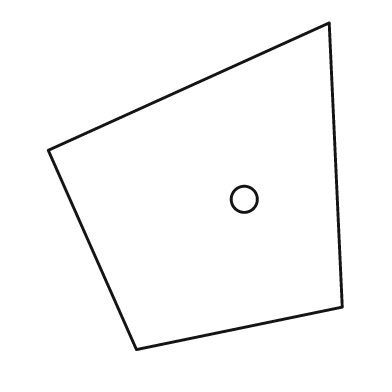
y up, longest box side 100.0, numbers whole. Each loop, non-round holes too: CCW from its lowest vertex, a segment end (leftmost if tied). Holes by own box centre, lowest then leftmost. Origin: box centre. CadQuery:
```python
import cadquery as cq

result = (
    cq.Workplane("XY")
    .moveTo(-18.0, -50.0)
    .lineTo(45.0, -37.0)
    .lineTo(41.0, 50.0)
    .lineTo(-45.0, 11.0)
    .close()
    .moveTo(15.0, -4.0)
    .circle(4.0)
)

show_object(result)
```